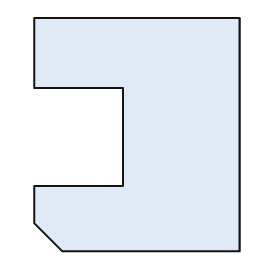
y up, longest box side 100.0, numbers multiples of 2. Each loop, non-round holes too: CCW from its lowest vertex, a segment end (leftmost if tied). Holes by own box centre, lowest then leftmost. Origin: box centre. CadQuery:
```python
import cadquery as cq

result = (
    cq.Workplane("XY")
    .moveTo(-32.0, -50.0)
    .lineTo(44.0, -50.0)
    .lineTo(44.0, 50.0)
    .lineTo(-44.0, 50.0)
    .lineTo(-44.0, 20.0)
    .lineTo(-6.0, 20.0)
    .lineTo(-6.0, -22.0)
    .lineTo(-44.0, -22.0)
    .lineTo(-44.0, -38.0)
    .close()
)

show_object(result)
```